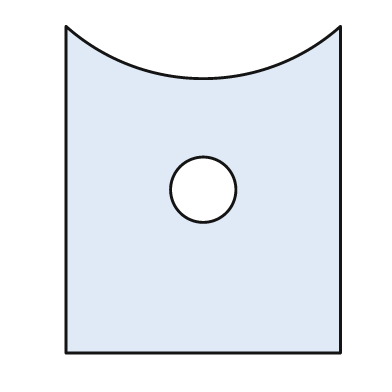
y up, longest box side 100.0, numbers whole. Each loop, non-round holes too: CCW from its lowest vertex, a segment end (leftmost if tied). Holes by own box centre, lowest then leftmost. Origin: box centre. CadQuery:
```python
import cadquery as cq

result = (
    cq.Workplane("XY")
    .moveTo(-42.0, -50.0)
    .lineTo(42.0, -50.0)
    .lineTo(42.0, 50.0)
    .threePointArc((0.0, 34.0), (-42.0, 50.0))
    .close()
    .moveTo(0.0, 0.0)
    .circle(10.0)
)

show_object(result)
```